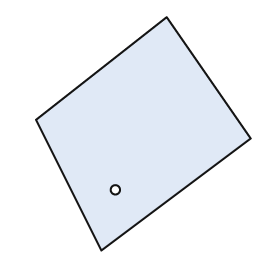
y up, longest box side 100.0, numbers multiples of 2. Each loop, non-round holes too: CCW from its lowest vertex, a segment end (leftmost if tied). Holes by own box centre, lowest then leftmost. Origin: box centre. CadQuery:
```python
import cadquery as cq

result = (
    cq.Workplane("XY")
    .moveTo(-18.0, -50.0)
    .lineTo(46.0, -2.0)
    .lineTo(10.0, 50.0)
    .lineTo(-46.0, 6.0)
    .close()
    .moveTo(-12.0, -24.0)
    .circle(2.0)
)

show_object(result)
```